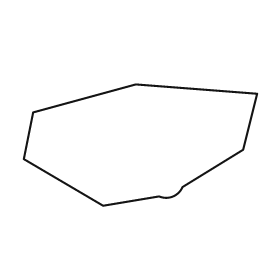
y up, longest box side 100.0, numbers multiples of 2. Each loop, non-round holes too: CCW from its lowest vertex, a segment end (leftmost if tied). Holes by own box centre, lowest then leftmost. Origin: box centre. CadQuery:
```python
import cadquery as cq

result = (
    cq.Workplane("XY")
    .moveTo(-16.0, -26.0)
    .lineTo(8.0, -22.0)
    .threePointArc((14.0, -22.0), (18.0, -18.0))
    .lineTo(44.0, -2.0)
    .lineTo(50.0, 22.0)
    .lineTo(-2.0, 26.0)
    .lineTo(-46.0, 14.0)
    .lineTo(-50.0, -6.0)
    .close()
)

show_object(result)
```